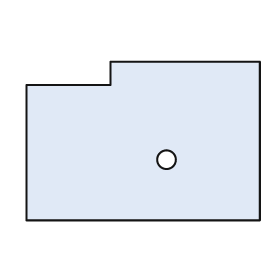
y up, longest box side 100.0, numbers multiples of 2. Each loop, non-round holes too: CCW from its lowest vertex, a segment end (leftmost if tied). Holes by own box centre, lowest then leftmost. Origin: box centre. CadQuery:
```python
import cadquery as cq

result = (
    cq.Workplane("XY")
    .moveTo(-50.0, -34.0)
    .lineTo(50.0, -34.0)
    .lineTo(50.0, 34.0)
    .lineTo(-14.0, 34.0)
    .lineTo(-14.0, 24.0)
    .lineTo(-50.0, 24.0)
    .close()
    .moveTo(10.0, -8.0)
    .circle(4.0)
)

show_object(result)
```